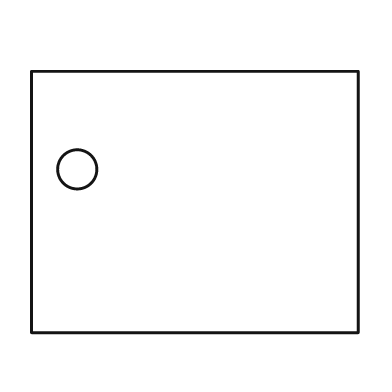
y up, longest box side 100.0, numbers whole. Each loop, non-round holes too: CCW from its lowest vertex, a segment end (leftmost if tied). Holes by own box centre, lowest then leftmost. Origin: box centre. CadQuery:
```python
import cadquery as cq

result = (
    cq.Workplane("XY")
    .moveTo(-50.0, -40.0)
    .lineTo(50.0, -40.0)
    .lineTo(50.0, 40.0)
    .lineTo(-50.0, 40.0)
    .close()
    .moveTo(-36.0, 10.0)
    .circle(6.0)
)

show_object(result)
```